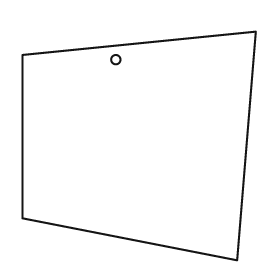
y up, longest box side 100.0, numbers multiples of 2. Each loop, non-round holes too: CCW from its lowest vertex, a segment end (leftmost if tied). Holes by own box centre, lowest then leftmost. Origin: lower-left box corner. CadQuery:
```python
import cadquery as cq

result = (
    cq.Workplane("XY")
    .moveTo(92.0, 0.0)
    .lineTo(100.0, 98.0)
    .lineTo(0.0, 88.0)
    .lineTo(0.0, 18.0)
    .close()
    .moveTo(40.0, 86.0)
    .circle(2.0)
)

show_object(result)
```